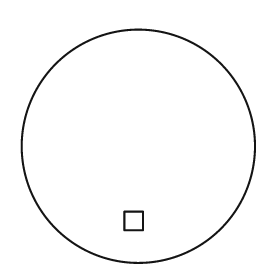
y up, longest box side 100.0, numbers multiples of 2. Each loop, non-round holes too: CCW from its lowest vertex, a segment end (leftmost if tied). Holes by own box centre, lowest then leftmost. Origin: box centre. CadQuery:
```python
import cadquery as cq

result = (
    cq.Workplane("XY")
    .moveTo(0.0, 0.0)
    .circle(50.0)
    .moveTo(-6.0, -36.0)
    .lineTo(2.0, -36.0)
    .lineTo(2.0, -28.0)
    .lineTo(-6.0, -28.0)
    .close()
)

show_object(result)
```